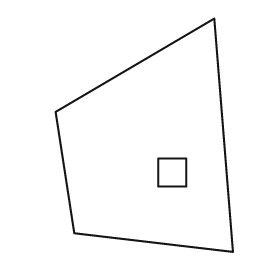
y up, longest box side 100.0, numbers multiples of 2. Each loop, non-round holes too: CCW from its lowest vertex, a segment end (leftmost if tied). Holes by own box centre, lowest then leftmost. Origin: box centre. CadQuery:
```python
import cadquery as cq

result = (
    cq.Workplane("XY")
    .moveTo(38.0, -50.0)
    .lineTo(30.0, 50.0)
    .lineTo(-38.0, 10.0)
    .lineTo(-30.0, -42.0)
    .close()
    .moveTo(6.0, -22.0)
    .lineTo(18.0, -22.0)
    .lineTo(18.0, -10.0)
    .lineTo(6.0, -10.0)
    .close()
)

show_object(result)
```